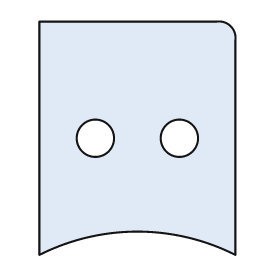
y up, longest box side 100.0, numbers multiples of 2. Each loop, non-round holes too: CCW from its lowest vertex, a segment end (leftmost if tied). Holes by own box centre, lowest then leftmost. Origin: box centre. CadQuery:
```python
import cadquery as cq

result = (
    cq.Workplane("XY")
    .moveTo(-42.0, -50.0)
    .threePointArc((0.0, -40.0), (42.0, -50.0))
    .lineTo(42.0, 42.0)
    .threePointArc((40.0, 48.0), (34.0, 50.0))
    .lineTo(-42.0, 50.0)
    .close()
    .moveTo(-18.0, 0.0)
    .circle(8.0)
    .moveTo(18.0, 0.0)
    .circle(8.0)
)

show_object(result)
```